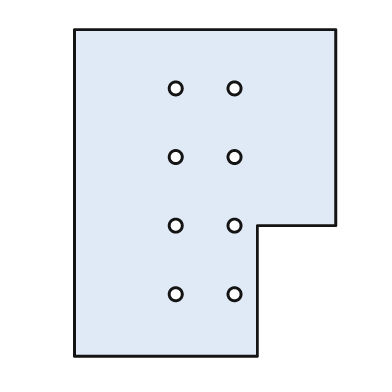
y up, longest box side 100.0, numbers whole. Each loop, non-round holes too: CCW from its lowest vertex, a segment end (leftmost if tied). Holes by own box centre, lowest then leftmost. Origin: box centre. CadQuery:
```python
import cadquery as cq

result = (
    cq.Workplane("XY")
    .moveTo(-40.0, -50.0)
    .lineTo(16.0, -50.0)
    .lineTo(16.0, -10.0)
    .lineTo(40.0, -10.0)
    .lineTo(40.0, 50.0)
    .lineTo(-40.0, 50.0)
    .close()
    .moveTo(-9.0, -31.0)
    .circle(2.0)
    .moveTo(9.0, -31.0)
    .circle(2.0)
    .moveTo(-9.0, -10.0)
    .circle(2.0)
    .moveTo(9.0, -10.0)
    .circle(2.0)
    .moveTo(-9.0, 11.0)
    .circle(2.0)
    .moveTo(9.0, 11.0)
    .circle(2.0)
    .moveTo(-9.0, 32.0)
    .circle(2.0)
    .moveTo(9.0, 32.0)
    .circle(2.0)
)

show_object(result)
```